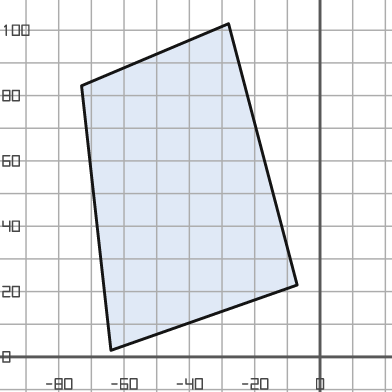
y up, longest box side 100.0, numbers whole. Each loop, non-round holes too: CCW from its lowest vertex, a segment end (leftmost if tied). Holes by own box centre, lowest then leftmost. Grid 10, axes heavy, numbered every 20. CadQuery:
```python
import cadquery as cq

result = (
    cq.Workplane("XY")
    .moveTo(-64.0, 2.0)
    .lineTo(-7.0, 22.0)
    .lineTo(-28.0, 102.0)
    .lineTo(-73.0, 83.0)
    .close()
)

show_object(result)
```